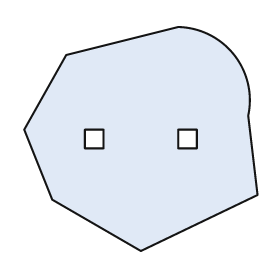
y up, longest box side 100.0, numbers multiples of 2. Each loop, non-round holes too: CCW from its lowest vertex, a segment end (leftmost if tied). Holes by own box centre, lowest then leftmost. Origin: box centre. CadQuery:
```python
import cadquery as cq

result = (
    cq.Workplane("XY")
    .moveTo(0.0, -48.0)
    .lineTo(50.0, -24.0)
    .lineTo(46.0, 10.0)
    .threePointArc((40.0, 36.0), (16.0, 48.0))
    .lineTo(-32.0, 36.0)
    .lineTo(-50.0, 4.0)
    .lineTo(-38.0, -26.0)
    .close()
    .moveTo(-24.0, -4.0)
    .lineTo(-16.0, -4.0)
    .lineTo(-16.0, 4.0)
    .lineTo(-24.0, 4.0)
    .close()
    .moveTo(16.0, -4.0)
    .lineTo(24.0, -4.0)
    .lineTo(24.0, 4.0)
    .lineTo(16.0, 4.0)
    .close()
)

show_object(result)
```